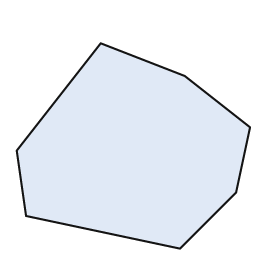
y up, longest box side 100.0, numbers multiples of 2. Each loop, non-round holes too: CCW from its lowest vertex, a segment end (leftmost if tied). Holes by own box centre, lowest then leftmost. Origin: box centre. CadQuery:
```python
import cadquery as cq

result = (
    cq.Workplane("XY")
    .moveTo(20.0, -44.0)
    .lineTo(44.0, -20.0)
    .lineTo(50.0, 8.0)
    .lineTo(22.0, 30.0)
    .lineTo(-14.0, 44.0)
    .lineTo(-50.0, -2.0)
    .lineTo(-46.0, -30.0)
    .close()
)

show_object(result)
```